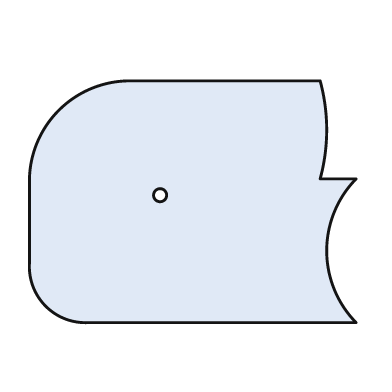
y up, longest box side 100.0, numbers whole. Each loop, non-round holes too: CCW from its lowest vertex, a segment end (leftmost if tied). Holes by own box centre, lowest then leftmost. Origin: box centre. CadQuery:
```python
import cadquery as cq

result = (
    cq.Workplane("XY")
    .moveTo(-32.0, -37.0)
    .lineTo(50.0, -37.0)
    .threePointArc((41.0, -15.0), (50.0, 7.0))
    .lineTo(39.0, 7.0)
    .threePointArc((41.0, 22.0), (39.0, 37.0))
    .lineTo(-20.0, 37.0)
    .threePointArc((-41.0, 28.0), (-50.0, 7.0))
    .lineTo(-50.0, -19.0)
    .threePointArc((-45.0, -32.0), (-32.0, -37.0))
    .close()
    .moveTo(-10.0, 2.0)
    .circle(2.0)
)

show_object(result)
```